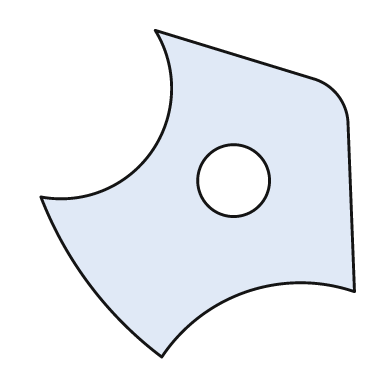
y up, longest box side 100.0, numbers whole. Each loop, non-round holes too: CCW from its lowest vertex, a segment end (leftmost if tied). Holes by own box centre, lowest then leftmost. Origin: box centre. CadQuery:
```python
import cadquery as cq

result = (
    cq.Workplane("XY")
    .moveTo(-11.0, -50.0)
    .threePointArc((15.0, -30.0), (48.0, -30.0))
    .lineTo(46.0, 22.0)
    .threePointArc((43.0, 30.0), (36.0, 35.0))
    .lineTo(-13.0, 50.0)
    .threePointArc((-14.0, 13.0), (-48.0, -1.0))
    .threePointArc((-33.0, -28.0), (-11.0, -50.0))
    .close()
    .moveTo(11.0, 4.0)
    .circle(11.0)
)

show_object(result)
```